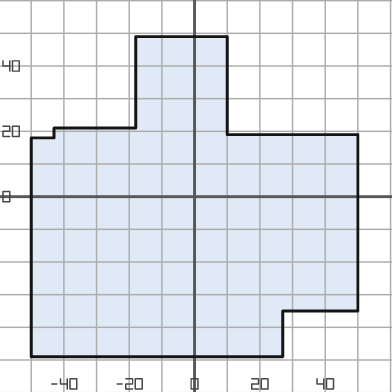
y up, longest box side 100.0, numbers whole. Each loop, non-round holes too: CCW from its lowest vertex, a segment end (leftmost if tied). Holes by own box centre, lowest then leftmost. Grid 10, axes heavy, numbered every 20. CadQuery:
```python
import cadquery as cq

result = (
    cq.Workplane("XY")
    .moveTo(-50.0, -49.0)
    .lineTo(27.0, -49.0)
    .lineTo(27.0, -35.0)
    .lineTo(50.0, -35.0)
    .lineTo(50.0, 19.0)
    .lineTo(10.0, 19.0)
    .lineTo(10.0, 49.0)
    .lineTo(-18.0, 49.0)
    .lineTo(-18.0, 21.0)
    .lineTo(-43.0, 21.0)
    .lineTo(-43.0, 18.0)
    .lineTo(-50.0, 18.0)
    .close()
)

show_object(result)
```